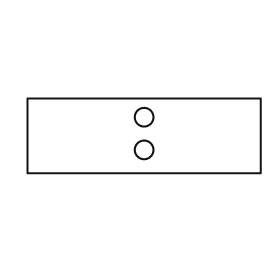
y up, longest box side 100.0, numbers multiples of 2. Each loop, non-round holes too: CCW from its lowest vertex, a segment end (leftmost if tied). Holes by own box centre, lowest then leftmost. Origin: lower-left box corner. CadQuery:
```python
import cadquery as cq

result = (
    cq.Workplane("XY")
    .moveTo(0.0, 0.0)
    .lineTo(100.0, 0.0)
    .lineTo(100.0, 32.0)
    .lineTo(0.0, 32.0)
    .close()
    .moveTo(50.0, 10.0)
    .circle(4.0)
    .moveTo(50.0, 24.0)
    .circle(4.0)
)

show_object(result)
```